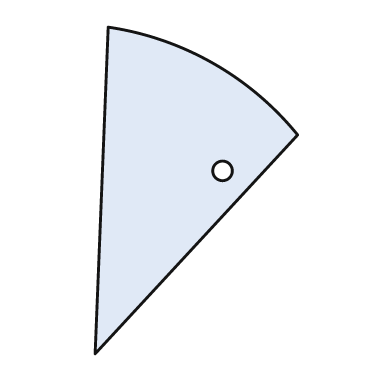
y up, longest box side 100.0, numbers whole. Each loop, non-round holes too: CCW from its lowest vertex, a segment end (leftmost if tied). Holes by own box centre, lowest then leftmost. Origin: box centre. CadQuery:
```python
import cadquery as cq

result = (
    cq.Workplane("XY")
    .moveTo(-31.0, -50.0)
    .lineTo(31.0, 17.0)
    .threePointArc((5.0, 39.0), (-27.0, 50.0))
    .close()
    .moveTo(8.0, 6.0)
    .circle(3.0)
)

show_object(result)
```